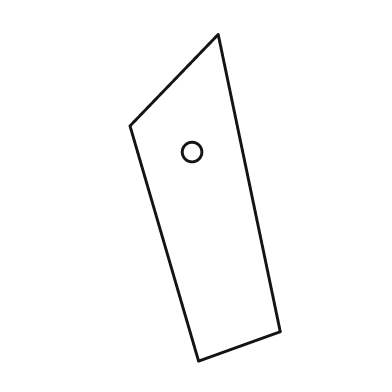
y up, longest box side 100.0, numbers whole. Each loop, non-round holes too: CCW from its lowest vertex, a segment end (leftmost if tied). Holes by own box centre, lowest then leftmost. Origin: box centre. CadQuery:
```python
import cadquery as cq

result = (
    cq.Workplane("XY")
    .moveTo(-2.0, -50.0)
    .lineTo(23.0, -41.0)
    .lineTo(4.0, 50.0)
    .lineTo(-23.0, 22.0)
    .close()
    .moveTo(-4.0, 14.0)
    .circle(3.0)
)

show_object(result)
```